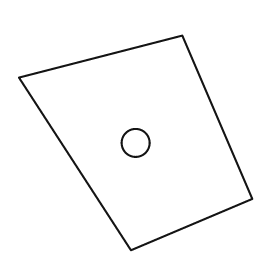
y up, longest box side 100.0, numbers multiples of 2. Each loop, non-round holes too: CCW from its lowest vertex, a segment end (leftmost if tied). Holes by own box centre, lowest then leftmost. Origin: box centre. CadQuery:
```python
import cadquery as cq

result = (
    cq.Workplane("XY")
    .moveTo(-2.0, -46.0)
    .lineTo(50.0, -24.0)
    .lineTo(20.0, 46.0)
    .lineTo(-50.0, 28.0)
    .close()
    .moveTo(0.0, 0.0)
    .circle(6.0)
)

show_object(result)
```